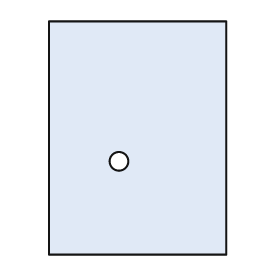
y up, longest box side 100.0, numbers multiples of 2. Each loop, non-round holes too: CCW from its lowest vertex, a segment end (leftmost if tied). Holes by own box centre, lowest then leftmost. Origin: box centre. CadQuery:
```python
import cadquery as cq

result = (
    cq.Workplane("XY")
    .moveTo(-38.0, -50.0)
    .lineTo(38.0, -50.0)
    .lineTo(38.0, 50.0)
    .lineTo(-38.0, 50.0)
    .close()
    .moveTo(-8.0, -10.0)
    .circle(4.0)
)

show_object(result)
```